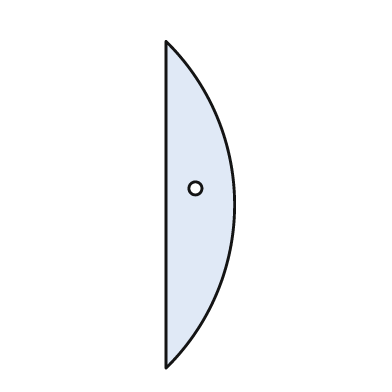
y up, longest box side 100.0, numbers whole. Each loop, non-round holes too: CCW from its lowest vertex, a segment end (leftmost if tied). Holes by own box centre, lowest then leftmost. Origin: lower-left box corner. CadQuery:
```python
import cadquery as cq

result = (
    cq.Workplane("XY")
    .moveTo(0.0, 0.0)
    .threePointArc((21.0, 50.0), (0.0, 100.0))
    .close()
    .moveTo(9.0, 55.0)
    .circle(2.0)
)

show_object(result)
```